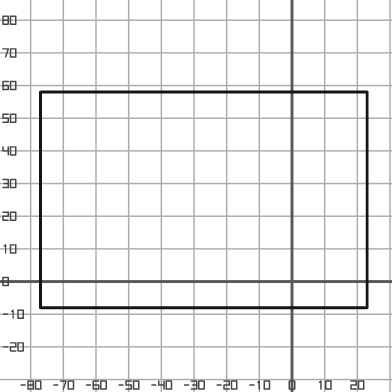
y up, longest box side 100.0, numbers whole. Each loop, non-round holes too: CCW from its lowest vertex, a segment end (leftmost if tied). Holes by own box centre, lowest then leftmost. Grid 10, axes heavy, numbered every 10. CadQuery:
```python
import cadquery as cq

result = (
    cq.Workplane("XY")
    .moveTo(-77.0, -8.0)
    .lineTo(23.0, -8.0)
    .lineTo(23.0, 58.0)
    .lineTo(-77.0, 58.0)
    .close()
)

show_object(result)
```